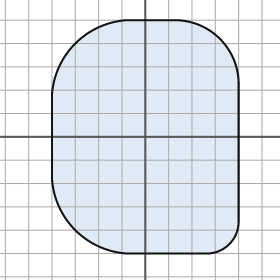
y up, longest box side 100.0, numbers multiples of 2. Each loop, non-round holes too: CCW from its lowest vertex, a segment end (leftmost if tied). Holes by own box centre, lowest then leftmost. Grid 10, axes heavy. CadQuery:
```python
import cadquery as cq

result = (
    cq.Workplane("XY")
    .moveTo(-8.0, -50.0)
    .lineTo(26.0, -50.0)
    .threePointArc((36.0, -46.0), (40.0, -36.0))
    .lineTo(40.0, 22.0)
    .threePointArc((32.0, 42.0), (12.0, 50.0))
    .lineTo(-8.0, 50.0)
    .threePointArc((-30.0, 40.0), (-40.0, 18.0))
    .lineTo(-40.0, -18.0)
    .threePointArc((-30.0, -40.0), (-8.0, -50.0))
    .close()
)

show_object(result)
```